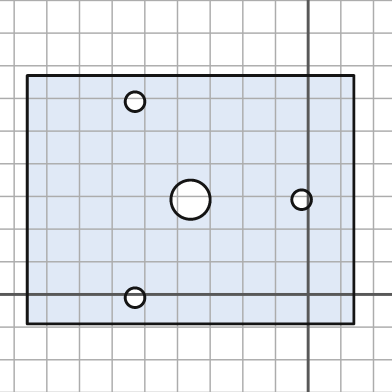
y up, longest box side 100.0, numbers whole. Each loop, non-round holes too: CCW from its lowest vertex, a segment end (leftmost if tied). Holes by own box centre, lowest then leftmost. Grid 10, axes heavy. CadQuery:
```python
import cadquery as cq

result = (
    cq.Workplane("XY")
    .moveTo(-86.0, -9.0)
    .lineTo(14.0, -9.0)
    .lineTo(14.0, 67.0)
    .lineTo(-86.0, 67.0)
    .close()
    .moveTo(-53.0, -1.0)
    .circle(3.0)
    .moveTo(-36.0, 29.0)
    .circle(6.0)
    .moveTo(-2.0, 29.0)
    .circle(3.0)
    .moveTo(-53.0, 59.0)
    .circle(3.0)
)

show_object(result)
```